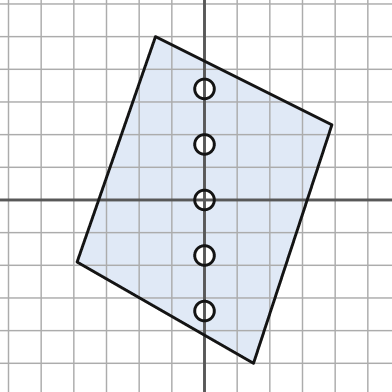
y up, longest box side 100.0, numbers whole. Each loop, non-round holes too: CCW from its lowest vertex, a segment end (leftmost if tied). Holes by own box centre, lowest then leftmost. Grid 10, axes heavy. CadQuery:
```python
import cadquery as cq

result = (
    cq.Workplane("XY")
    .moveTo(15.0, -50.0)
    .lineTo(39.0, 23.0)
    .lineTo(-15.0, 50.0)
    .lineTo(-39.0, -19.0)
    .close()
    .moveTo(0.0, -34.0)
    .circle(3.0)
    .moveTo(0.0, -17.0)
    .circle(3.0)
    .moveTo(0.0, 0.0)
    .circle(3.0)
    .moveTo(0.0, 17.0)
    .circle(3.0)
    .moveTo(0.0, 34.0)
    .circle(3.0)
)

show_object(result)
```